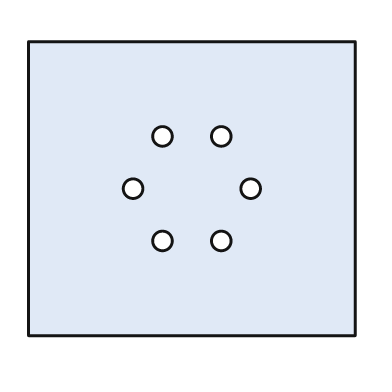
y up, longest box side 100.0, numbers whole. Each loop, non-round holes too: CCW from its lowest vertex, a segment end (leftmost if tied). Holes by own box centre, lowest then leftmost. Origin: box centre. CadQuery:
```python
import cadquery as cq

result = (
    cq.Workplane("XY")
    .moveTo(-50.0, -45.0)
    .lineTo(50.0, -45.0)
    .lineTo(50.0, 45.0)
    .lineTo(-50.0, 45.0)
    .close()
    .moveTo(-9.0, -16.0)
    .circle(3.0)
    .moveTo(9.0, -16.0)
    .circle(3.0)
    .moveTo(-18.0, 0.0)
    .circle(3.0)
    .moveTo(18.0, 0.0)
    .circle(3.0)
    .moveTo(-9.0, 16.0)
    .circle(3.0)
    .moveTo(9.0, 16.0)
    .circle(3.0)
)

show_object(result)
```